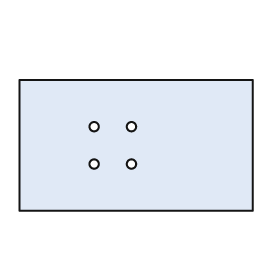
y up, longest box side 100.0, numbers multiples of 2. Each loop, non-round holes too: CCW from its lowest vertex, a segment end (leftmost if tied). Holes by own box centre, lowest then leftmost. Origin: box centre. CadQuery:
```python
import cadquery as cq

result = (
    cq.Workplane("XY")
    .moveTo(-50.0, -28.0)
    .lineTo(50.0, -28.0)
    .lineTo(50.0, 28.0)
    .lineTo(-50.0, 28.0)
    .close()
    .moveTo(-18.0, -8.0)
    .circle(2.0)
    .moveTo(-2.0, -8.0)
    .circle(2.0)
    .moveTo(-18.0, 8.0)
    .circle(2.0)
    .moveTo(-2.0, 8.0)
    .circle(2.0)
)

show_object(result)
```